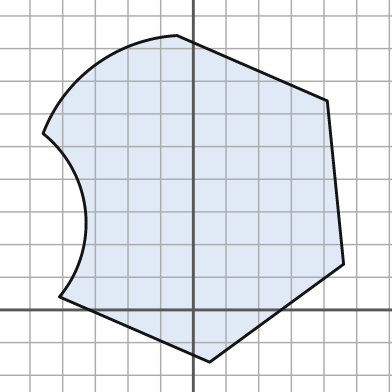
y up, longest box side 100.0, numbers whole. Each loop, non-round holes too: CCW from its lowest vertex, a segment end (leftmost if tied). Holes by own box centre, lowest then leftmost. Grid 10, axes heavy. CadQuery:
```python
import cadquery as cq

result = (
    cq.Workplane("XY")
    .moveTo(5.0, -16.0)
    .lineTo(46.0, 14.0)
    .lineTo(41.0, 64.0)
    .lineTo(-5.0, 84.0)
    .threePointArc((-30.0, 75.0), (-46.0, 54.0))
    .threePointArc((-33.0, 30.0), (-41.0, 4.0))
    .close()
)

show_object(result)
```